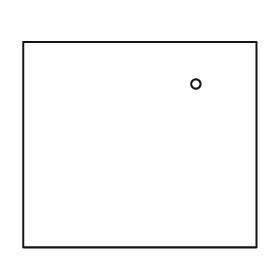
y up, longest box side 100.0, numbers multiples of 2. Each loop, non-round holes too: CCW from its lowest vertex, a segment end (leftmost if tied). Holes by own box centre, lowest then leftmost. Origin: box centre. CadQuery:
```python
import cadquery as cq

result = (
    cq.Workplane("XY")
    .moveTo(-50.0, -44.0)
    .lineTo(50.0, -44.0)
    .lineTo(50.0, 44.0)
    .lineTo(-50.0, 44.0)
    .close()
    .moveTo(24.0, 26.0)
    .circle(2.0)
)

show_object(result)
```